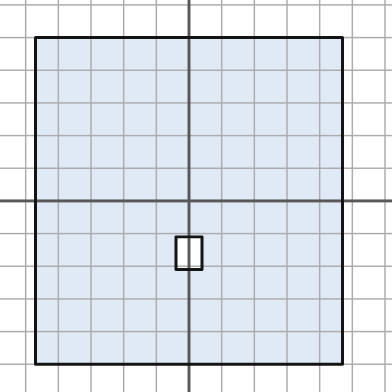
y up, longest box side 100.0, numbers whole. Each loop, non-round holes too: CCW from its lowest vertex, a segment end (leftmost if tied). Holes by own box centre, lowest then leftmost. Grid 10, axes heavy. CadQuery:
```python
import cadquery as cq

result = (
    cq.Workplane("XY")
    .moveTo(-47.0, -50.0)
    .lineTo(47.0, -50.0)
    .lineTo(47.0, 50.0)
    .lineTo(-47.0, 50.0)
    .close()
    .moveTo(-4.0, -21.0)
    .lineTo(4.0, -21.0)
    .lineTo(4.0, -11.0)
    .lineTo(-4.0, -11.0)
    .close()
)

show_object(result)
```